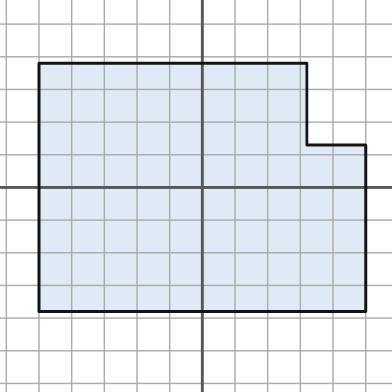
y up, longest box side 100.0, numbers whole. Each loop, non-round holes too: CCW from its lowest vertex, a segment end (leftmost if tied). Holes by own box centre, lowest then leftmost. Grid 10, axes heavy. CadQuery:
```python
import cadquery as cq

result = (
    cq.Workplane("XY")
    .moveTo(-50.0, -38.0)
    .lineTo(50.0, -38.0)
    .lineTo(50.0, 13.0)
    .lineTo(32.0, 13.0)
    .lineTo(32.0, 38.0)
    .lineTo(-50.0, 38.0)
    .close()
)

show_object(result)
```